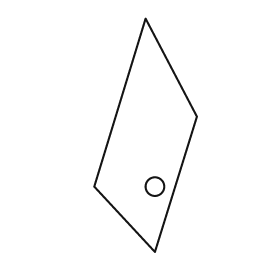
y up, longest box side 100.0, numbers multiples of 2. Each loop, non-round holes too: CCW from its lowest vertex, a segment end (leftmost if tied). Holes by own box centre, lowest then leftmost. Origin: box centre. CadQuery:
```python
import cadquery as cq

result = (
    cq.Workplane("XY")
    .moveTo(4.0, -50.0)
    .lineTo(22.0, 8.0)
    .lineTo(0.0, 50.0)
    .lineTo(-22.0, -22.0)
    .close()
    .moveTo(4.0, -22.0)
    .circle(4.0)
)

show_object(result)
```